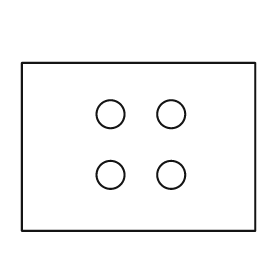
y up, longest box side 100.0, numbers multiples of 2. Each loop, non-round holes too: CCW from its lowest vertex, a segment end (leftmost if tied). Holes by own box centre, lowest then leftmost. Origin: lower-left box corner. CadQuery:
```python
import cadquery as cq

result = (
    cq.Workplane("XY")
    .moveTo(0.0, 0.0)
    .lineTo(100.0, 0.0)
    .lineTo(100.0, 72.0)
    .lineTo(0.0, 72.0)
    .close()
    .moveTo(38.0, 24.0)
    .circle(6.0)
    .moveTo(64.0, 24.0)
    .circle(6.0)
    .moveTo(38.0, 50.0)
    .circle(6.0)
    .moveTo(64.0, 50.0)
    .circle(6.0)
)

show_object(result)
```